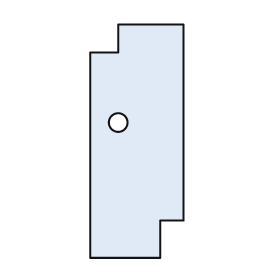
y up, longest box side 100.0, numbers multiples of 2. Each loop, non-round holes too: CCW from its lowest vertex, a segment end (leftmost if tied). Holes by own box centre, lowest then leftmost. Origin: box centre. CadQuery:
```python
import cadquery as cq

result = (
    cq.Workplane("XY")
    .moveTo(-20.0, -50.0)
    .lineTo(10.0, -50.0)
    .lineTo(10.0, -34.0)
    .lineTo(20.0, -34.0)
    .lineTo(20.0, 50.0)
    .lineTo(-8.0, 50.0)
    .lineTo(-8.0, 38.0)
    .lineTo(-20.0, 38.0)
    .close()
    .moveTo(-8.0, 8.0)
    .circle(4.0)
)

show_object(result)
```